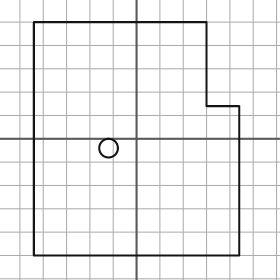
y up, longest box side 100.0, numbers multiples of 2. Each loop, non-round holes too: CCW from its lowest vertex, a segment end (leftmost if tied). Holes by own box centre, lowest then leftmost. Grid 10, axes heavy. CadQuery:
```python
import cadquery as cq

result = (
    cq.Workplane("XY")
    .moveTo(-44.0, -50.0)
    .lineTo(44.0, -50.0)
    .lineTo(44.0, 14.0)
    .lineTo(30.0, 14.0)
    .lineTo(30.0, 50.0)
    .lineTo(-44.0, 50.0)
    .close()
    .moveTo(-12.0, -4.0)
    .circle(4.0)
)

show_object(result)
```